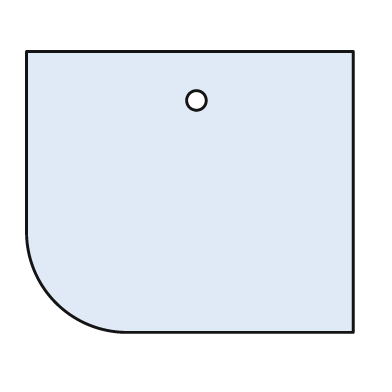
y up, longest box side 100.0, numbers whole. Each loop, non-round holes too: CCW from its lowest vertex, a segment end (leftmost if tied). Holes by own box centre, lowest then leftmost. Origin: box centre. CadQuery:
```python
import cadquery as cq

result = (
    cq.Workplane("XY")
    .moveTo(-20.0, -43.0)
    .lineTo(50.0, -43.0)
    .lineTo(50.0, 43.0)
    .lineTo(-50.0, 43.0)
    .lineTo(-50.0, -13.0)
    .threePointArc((-41.0, -34.0), (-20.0, -43.0))
    .close()
    .moveTo(2.0, 28.0)
    .circle(3.0)
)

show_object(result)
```